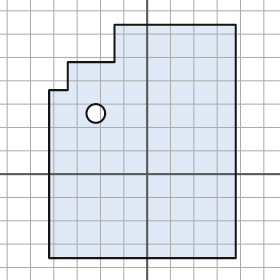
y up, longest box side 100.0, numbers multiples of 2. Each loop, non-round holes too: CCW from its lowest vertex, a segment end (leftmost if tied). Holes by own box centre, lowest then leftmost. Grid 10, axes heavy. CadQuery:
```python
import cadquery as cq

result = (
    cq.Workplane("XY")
    .moveTo(-42.0, -36.0)
    .lineTo(38.0, -36.0)
    .lineTo(38.0, 64.0)
    .lineTo(-14.0, 64.0)
    .lineTo(-14.0, 48.0)
    .lineTo(-34.0, 48.0)
    .lineTo(-34.0, 36.0)
    .lineTo(-42.0, 36.0)
    .close()
    .moveTo(-22.0, 26.0)
    .circle(4.0)
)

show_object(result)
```